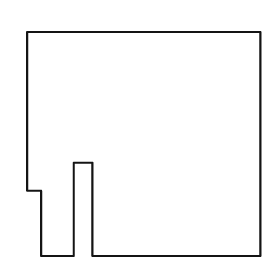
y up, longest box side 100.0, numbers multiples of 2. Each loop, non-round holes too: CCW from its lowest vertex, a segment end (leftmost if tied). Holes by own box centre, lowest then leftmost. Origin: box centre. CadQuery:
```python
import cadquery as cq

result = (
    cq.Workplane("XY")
    .moveTo(-44.0, -48.0)
    .lineTo(-30.0, -48.0)
    .lineTo(-30.0, -8.0)
    .lineTo(-22.0, -8.0)
    .lineTo(-22.0, -48.0)
    .lineTo(50.0, -48.0)
    .lineTo(50.0, 48.0)
    .lineTo(-50.0, 48.0)
    .lineTo(-50.0, -20.0)
    .lineTo(-44.0, -20.0)
    .close()
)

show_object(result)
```